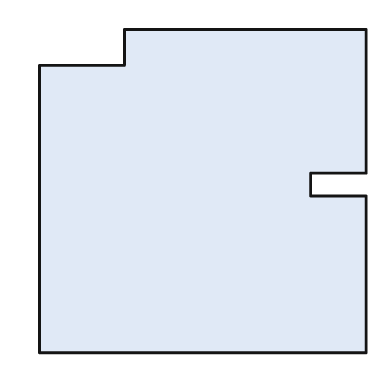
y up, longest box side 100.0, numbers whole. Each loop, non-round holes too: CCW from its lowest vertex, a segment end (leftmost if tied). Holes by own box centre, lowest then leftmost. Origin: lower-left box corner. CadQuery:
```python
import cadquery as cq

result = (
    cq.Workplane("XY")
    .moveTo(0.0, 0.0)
    .lineTo(100.0, 0.0)
    .lineTo(100.0, 48.0)
    .lineTo(83.0, 48.0)
    .lineTo(83.0, 55.0)
    .lineTo(100.0, 55.0)
    .lineTo(100.0, 99.0)
    .lineTo(26.0, 99.0)
    .lineTo(26.0, 88.0)
    .lineTo(0.0, 88.0)
    .close()
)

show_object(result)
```